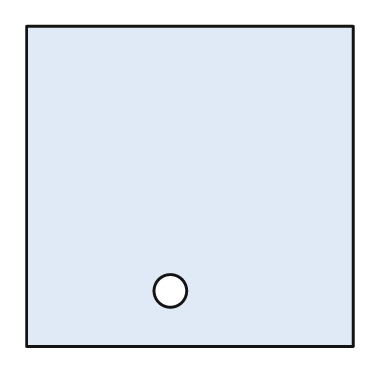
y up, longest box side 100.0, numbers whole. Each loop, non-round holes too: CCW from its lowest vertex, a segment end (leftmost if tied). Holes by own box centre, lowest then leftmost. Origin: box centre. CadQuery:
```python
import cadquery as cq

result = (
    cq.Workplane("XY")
    .moveTo(-50.0, -49.0)
    .lineTo(50.0, -49.0)
    .lineTo(50.0, 49.0)
    .lineTo(-50.0, 49.0)
    .close()
    .moveTo(-6.0, -32.0)
    .circle(5.0)
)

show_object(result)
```